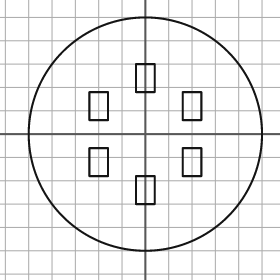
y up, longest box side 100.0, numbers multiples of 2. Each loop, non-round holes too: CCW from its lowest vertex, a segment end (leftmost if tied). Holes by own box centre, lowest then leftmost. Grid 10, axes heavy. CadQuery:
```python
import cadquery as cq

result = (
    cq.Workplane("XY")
    .moveTo(0.0, 0.0)
    .circle(50.0)
    .moveTo(-4.0, -30.0)
    .lineTo(4.0, -30.0)
    .lineTo(4.0, -18.0)
    .lineTo(-4.0, -18.0)
    .close()
    .moveTo(-24.0, -18.0)
    .lineTo(-16.0, -18.0)
    .lineTo(-16.0, -6.0)
    .lineTo(-24.0, -6.0)
    .close()
    .moveTo(16.0, -18.0)
    .lineTo(24.0, -18.0)
    .lineTo(24.0, -6.0)
    .lineTo(16.0, -6.0)
    .close()
    .moveTo(-24.0, 6.0)
    .lineTo(-16.0, 6.0)
    .lineTo(-16.0, 18.0)
    .lineTo(-24.0, 18.0)
    .close()
    .moveTo(16.0, 6.0)
    .lineTo(24.0, 6.0)
    .lineTo(24.0, 18.0)
    .lineTo(16.0, 18.0)
    .close()
    .moveTo(-4.0, 18.0)
    .lineTo(4.0, 18.0)
    .lineTo(4.0, 30.0)
    .lineTo(-4.0, 30.0)
    .close()
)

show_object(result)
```